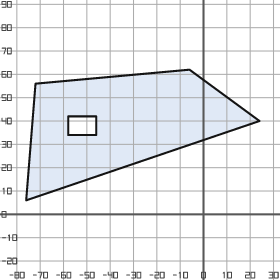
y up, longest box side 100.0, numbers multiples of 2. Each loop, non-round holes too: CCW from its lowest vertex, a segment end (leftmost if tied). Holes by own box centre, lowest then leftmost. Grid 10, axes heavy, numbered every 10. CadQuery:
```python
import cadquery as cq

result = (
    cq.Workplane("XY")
    .moveTo(-76.0, 6.0)
    .lineTo(24.0, 40.0)
    .lineTo(-6.0, 62.0)
    .lineTo(-72.0, 56.0)
    .close()
    .moveTo(-58.0, 34.0)
    .lineTo(-46.0, 34.0)
    .lineTo(-46.0, 42.0)
    .lineTo(-58.0, 42.0)
    .close()
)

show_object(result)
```